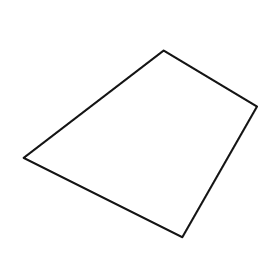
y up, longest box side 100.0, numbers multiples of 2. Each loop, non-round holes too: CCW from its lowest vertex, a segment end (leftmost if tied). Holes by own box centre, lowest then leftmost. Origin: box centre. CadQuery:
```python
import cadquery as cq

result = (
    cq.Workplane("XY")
    .moveTo(18.0, -40.0)
    .lineTo(50.0, 16.0)
    .lineTo(10.0, 40.0)
    .lineTo(-50.0, -6.0)
    .close()
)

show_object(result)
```